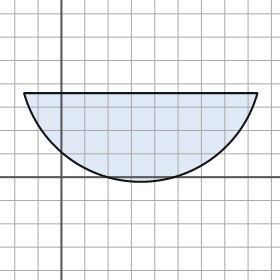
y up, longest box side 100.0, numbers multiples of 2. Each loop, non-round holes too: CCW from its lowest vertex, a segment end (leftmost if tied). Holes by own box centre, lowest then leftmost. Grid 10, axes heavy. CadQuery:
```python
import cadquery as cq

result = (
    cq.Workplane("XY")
    .moveTo(-16.0, 36.0)
    .threePointArc((34.0, -2.0), (84.0, 36.0))
    .close()
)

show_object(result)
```